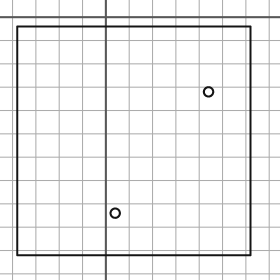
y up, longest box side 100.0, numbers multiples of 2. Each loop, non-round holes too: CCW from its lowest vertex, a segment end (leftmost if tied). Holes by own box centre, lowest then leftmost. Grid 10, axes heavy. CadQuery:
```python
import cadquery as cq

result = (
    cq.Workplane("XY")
    .moveTo(-38.0, -102.0)
    .lineTo(62.0, -102.0)
    .lineTo(62.0, -4.0)
    .lineTo(-38.0, -4.0)
    .close()
    .moveTo(4.0, -84.0)
    .circle(2.0)
    .moveTo(44.0, -32.0)
    .circle(2.0)
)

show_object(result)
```